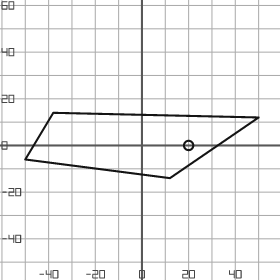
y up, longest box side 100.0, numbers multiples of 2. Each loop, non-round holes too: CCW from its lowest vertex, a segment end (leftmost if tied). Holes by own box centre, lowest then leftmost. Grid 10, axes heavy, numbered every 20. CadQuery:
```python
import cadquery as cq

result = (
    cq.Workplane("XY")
    .moveTo(12.0, -14.0)
    .lineTo(50.0, 12.0)
    .lineTo(-38.0, 14.0)
    .lineTo(-50.0, -6.0)
    .close()
    .moveTo(20.0, 0.0)
    .circle(2.0)
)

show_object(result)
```